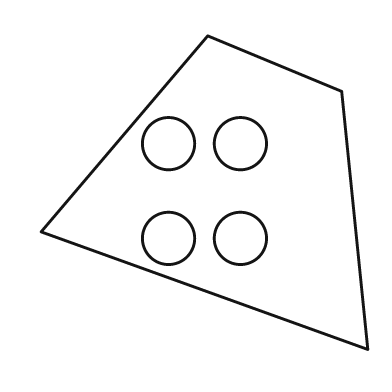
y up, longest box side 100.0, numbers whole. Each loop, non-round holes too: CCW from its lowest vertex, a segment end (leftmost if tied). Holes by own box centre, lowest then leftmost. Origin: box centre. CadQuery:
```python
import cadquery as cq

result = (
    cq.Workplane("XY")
    .moveTo(50.0, -48.0)
    .lineTo(42.0, 31.0)
    .lineTo(1.0, 48.0)
    .lineTo(-50.0, -12.0)
    .close()
    .moveTo(-11.0, -14.0)
    .circle(8.0)
    .moveTo(11.0, -14.0)
    .circle(8.0)
    .moveTo(-11.0, 15.0)
    .circle(8.0)
    .moveTo(11.0, 15.0)
    .circle(8.0)
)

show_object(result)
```